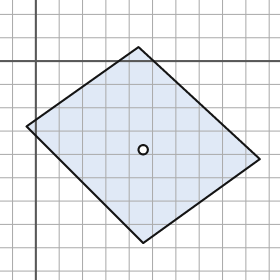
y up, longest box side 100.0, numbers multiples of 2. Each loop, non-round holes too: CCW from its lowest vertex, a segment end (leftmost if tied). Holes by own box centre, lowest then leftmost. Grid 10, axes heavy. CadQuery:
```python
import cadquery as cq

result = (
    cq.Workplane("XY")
    .moveTo(46.0, -78.0)
    .lineTo(96.0, -42.0)
    .lineTo(44.0, 6.0)
    .lineTo(-4.0, -28.0)
    .close()
    .moveTo(46.0, -38.0)
    .circle(2.0)
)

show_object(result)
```